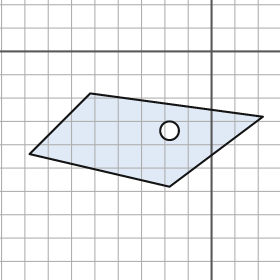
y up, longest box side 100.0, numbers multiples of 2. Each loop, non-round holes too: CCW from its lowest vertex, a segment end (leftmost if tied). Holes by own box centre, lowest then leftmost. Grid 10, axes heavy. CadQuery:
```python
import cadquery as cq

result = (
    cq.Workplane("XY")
    .moveTo(-18.0, -58.0)
    .lineTo(22.0, -28.0)
    .lineTo(-52.0, -18.0)
    .lineTo(-78.0, -44.0)
    .close()
    .moveTo(-18.0, -34.0)
    .circle(4.0)
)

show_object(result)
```